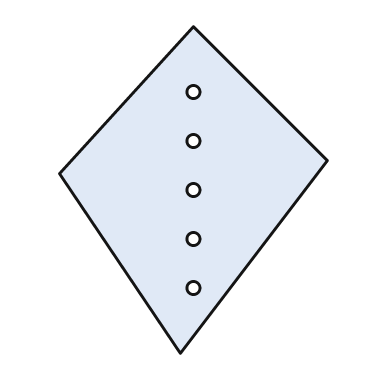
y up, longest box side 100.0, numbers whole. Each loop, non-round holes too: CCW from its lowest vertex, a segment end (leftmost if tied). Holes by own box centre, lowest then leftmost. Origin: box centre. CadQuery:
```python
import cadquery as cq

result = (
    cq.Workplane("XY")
    .moveTo(-4.0, -50.0)
    .lineTo(41.0, 9.0)
    .lineTo(0.0, 50.0)
    .lineTo(-41.0, 5.0)
    .close()
    .moveTo(0.0, -30.0)
    .circle(2.0)
    .moveTo(0.0, -15.0)
    .circle(2.0)
    .moveTo(0.0, 0.0)
    .circle(2.0)
    .moveTo(0.0, 15.0)
    .circle(2.0)
    .moveTo(0.0, 30.0)
    .circle(2.0)
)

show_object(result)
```